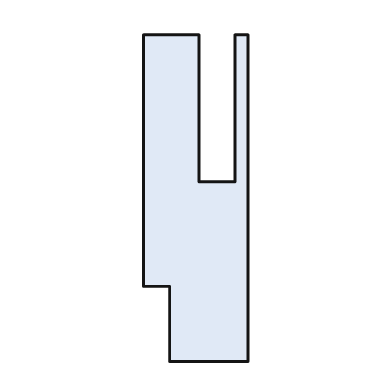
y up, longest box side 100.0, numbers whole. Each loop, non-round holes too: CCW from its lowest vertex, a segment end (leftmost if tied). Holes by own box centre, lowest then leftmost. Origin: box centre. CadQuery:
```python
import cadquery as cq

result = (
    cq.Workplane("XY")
    .moveTo(-8.0, -50.0)
    .lineTo(16.0, -50.0)
    .lineTo(16.0, 50.0)
    .lineTo(12.0, 50.0)
    .lineTo(12.0, 5.0)
    .lineTo(1.0, 5.0)
    .lineTo(1.0, 50.0)
    .lineTo(-16.0, 50.0)
    .lineTo(-16.0, -27.0)
    .lineTo(-8.0, -27.0)
    .close()
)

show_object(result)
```